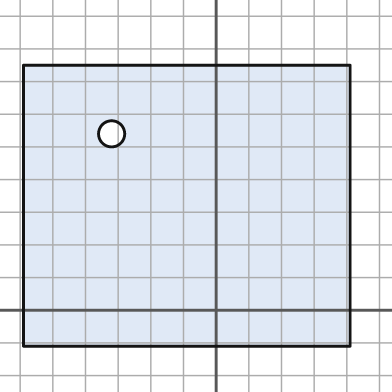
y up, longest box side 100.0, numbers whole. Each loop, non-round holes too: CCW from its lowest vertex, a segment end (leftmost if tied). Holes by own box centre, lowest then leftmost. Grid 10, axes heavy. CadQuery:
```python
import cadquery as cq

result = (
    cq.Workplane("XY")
    .moveTo(-59.0, -11.0)
    .lineTo(41.0, -11.0)
    .lineTo(41.0, 75.0)
    .lineTo(-59.0, 75.0)
    .close()
    .moveTo(-32.0, 54.0)
    .circle(4.0)
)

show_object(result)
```